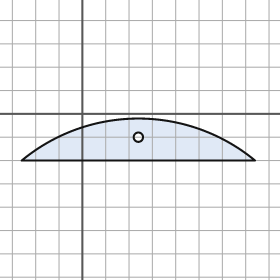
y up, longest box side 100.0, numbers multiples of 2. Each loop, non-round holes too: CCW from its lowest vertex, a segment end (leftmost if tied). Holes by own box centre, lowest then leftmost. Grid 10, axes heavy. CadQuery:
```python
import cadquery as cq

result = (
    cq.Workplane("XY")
    .moveTo(-26.0, -20.0)
    .lineTo(74.0, -20.0)
    .threePointArc((24.0, -2.0), (-26.0, -20.0))
    .close()
    .moveTo(24.0, -10.0)
    .circle(2.0)
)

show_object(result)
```